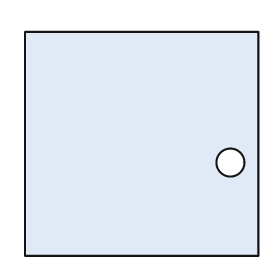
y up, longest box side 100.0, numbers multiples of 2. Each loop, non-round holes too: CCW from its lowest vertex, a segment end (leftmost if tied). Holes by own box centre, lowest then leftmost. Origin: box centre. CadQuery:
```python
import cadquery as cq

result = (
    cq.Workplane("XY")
    .moveTo(-50.0, -48.0)
    .lineTo(50.0, -48.0)
    .lineTo(50.0, 48.0)
    .lineTo(-50.0, 48.0)
    .close()
    .moveTo(38.0, -8.0)
    .circle(6.0)
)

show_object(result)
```